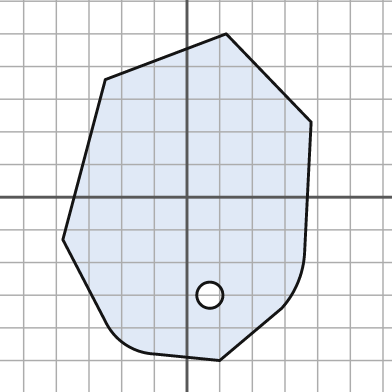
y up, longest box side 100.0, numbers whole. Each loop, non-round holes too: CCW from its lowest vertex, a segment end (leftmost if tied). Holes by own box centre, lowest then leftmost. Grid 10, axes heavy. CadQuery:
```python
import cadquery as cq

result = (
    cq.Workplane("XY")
    .moveTo(10.0, -50.0)
    .lineTo(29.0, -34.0)
    .threePointArc((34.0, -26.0), (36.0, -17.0))
    .lineTo(38.0, 23.0)
    .lineTo(12.0, 50.0)
    .lineTo(-25.0, 36.0)
    .lineTo(-38.0, -13.0)
    .lineTo(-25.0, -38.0)
    .threePointArc((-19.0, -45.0), (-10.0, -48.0))
    .close()
    .moveTo(7.0, -30.0)
    .circle(4.0)
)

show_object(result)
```